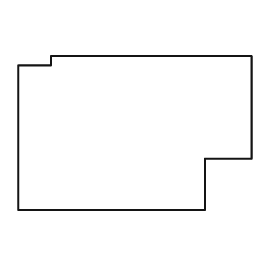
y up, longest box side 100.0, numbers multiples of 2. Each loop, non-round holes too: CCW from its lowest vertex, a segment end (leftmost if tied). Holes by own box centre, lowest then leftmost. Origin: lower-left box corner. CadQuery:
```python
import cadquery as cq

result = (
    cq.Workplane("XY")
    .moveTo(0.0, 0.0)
    .lineTo(80.0, 0.0)
    .lineTo(80.0, 22.0)
    .lineTo(100.0, 22.0)
    .lineTo(100.0, 66.0)
    .lineTo(14.0, 66.0)
    .lineTo(14.0, 62.0)
    .lineTo(0.0, 62.0)
    .close()
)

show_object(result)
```